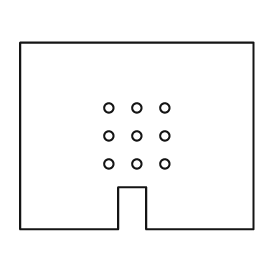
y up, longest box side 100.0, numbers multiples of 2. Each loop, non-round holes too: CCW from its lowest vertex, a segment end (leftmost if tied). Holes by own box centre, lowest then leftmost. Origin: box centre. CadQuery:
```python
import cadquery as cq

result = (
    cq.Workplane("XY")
    .moveTo(-50.0, -40.0)
    .lineTo(-8.0, -40.0)
    .lineTo(-8.0, -22.0)
    .lineTo(4.0, -22.0)
    .lineTo(4.0, -40.0)
    .lineTo(50.0, -40.0)
    .lineTo(50.0, 40.0)
    .lineTo(-50.0, 40.0)
    .close()
    .moveTo(-12.0, -12.0)
    .circle(2.0)
    .moveTo(0.0, -12.0)
    .circle(2.0)
    .moveTo(12.0, -12.0)
    .circle(2.0)
    .moveTo(-12.0, 0.0)
    .circle(2.0)
    .moveTo(0.0, 0.0)
    .circle(2.0)
    .moveTo(12.0, 0.0)
    .circle(2.0)
    .moveTo(-12.0, 12.0)
    .circle(2.0)
    .moveTo(0.0, 12.0)
    .circle(2.0)
    .moveTo(12.0, 12.0)
    .circle(2.0)
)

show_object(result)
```